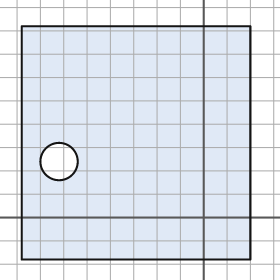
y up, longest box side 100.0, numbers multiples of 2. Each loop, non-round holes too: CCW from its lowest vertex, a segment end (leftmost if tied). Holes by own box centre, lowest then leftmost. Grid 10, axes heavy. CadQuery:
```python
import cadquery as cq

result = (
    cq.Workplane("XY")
    .moveTo(-78.0, -18.0)
    .lineTo(20.0, -18.0)
    .lineTo(20.0, 82.0)
    .lineTo(-78.0, 82.0)
    .close()
    .moveTo(-62.0, 24.0)
    .circle(8.0)
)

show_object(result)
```